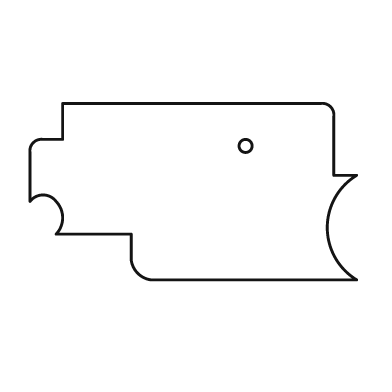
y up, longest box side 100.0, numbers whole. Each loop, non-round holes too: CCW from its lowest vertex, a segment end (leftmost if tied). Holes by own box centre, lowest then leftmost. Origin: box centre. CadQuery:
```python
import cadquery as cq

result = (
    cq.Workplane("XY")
    .moveTo(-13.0, -27.0)
    .lineTo(50.0, -27.0)
    .threePointArc((41.0, -11.0), (50.0, 5.0))
    .lineTo(43.0, 5.0)
    .lineTo(43.0, 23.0)
    .threePointArc((42.0, 26.0), (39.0, 27.0))
    .lineTo(-40.0, 27.0)
    .lineTo(-40.0, 16.0)
    .lineTo(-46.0, 16.0)
    .threePointArc((-49.0, 15.0), (-50.0, 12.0))
    .lineTo(-50.0, -3.0)
    .threePointArc((-46.0, -1.0), (-42.0, -3.0))
    .threePointArc((-40.0, -8.0), (-42.0, -13.0))
    .lineTo(-19.0, -13.0)
    .lineTo(-19.0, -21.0)
    .threePointArc((-17.0, -25.0), (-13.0, -27.0))
    .close()
    .moveTo(16.0, 14.0)
    .circle(2.0)
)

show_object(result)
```